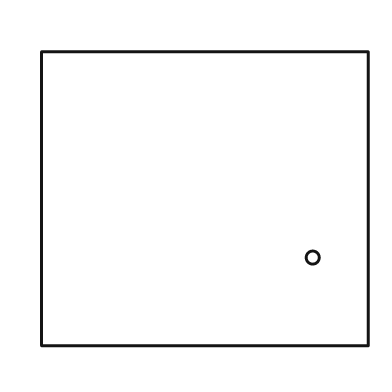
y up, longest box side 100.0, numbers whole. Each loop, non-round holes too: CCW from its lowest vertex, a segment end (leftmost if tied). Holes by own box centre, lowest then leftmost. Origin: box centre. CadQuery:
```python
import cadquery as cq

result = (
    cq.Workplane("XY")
    .moveTo(-50.0, -45.0)
    .lineTo(50.0, -45.0)
    .lineTo(50.0, 45.0)
    .lineTo(-50.0, 45.0)
    .close()
    .moveTo(33.0, -18.0)
    .circle(2.0)
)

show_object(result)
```